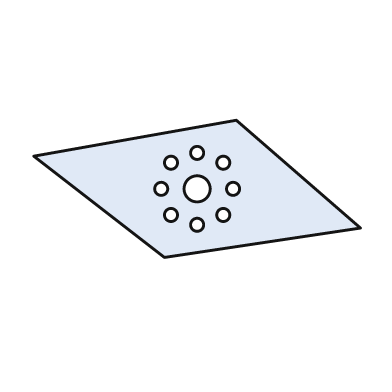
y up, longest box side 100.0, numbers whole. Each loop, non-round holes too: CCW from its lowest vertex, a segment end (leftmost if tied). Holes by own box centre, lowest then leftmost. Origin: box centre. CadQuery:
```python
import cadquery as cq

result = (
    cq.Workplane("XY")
    .moveTo(-10.0, -21.0)
    .lineTo(50.0, -12.0)
    .lineTo(12.0, 21.0)
    .lineTo(-50.0, 10.0)
    .close()
    .moveTo(0.0, -11.0)
    .circle(2.0)
    .moveTo(-8.0, -8.0)
    .circle(2.0)
    .moveTo(8.0, -8.0)
    .circle(2.0)
    .moveTo(-11.0, 0.0)
    .circle(2.0)
    .moveTo(0.0, 0.0)
    .circle(4.0)
    .moveTo(11.0, 0.0)
    .circle(2.0)
    .moveTo(-8.0, 8.0)
    .circle(2.0)
    .moveTo(8.0, 8.0)
    .circle(2.0)
    .moveTo(0.0, 11.0)
    .circle(2.0)
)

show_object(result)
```